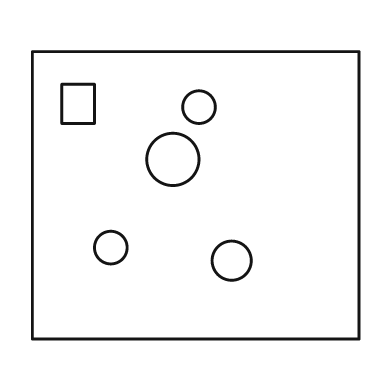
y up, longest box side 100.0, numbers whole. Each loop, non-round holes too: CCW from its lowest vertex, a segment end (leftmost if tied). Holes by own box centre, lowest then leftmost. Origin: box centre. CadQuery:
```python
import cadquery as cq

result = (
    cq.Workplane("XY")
    .moveTo(-50.0, -44.0)
    .lineTo(50.0, -44.0)
    .lineTo(50.0, 44.0)
    .lineTo(-50.0, 44.0)
    .close()
    .moveTo(11.0, -20.0)
    .circle(6.0)
    .moveTo(-26.0, -16.0)
    .circle(5.0)
    .moveTo(-7.0, 11.0)
    .circle(8.0)
    .moveTo(1.0, 27.0)
    .circle(5.0)
    .moveTo(-41.0, 22.0)
    .lineTo(-31.0, 22.0)
    .lineTo(-31.0, 34.0)
    .lineTo(-41.0, 34.0)
    .close()
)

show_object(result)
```